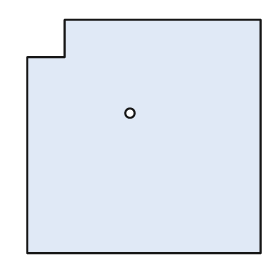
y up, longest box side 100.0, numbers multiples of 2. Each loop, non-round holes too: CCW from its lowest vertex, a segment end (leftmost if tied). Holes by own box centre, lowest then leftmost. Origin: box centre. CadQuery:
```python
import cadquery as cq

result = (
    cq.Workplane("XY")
    .moveTo(-50.0, -50.0)
    .lineTo(50.0, -50.0)
    .lineTo(50.0, 50.0)
    .lineTo(-34.0, 50.0)
    .lineTo(-34.0, 34.0)
    .lineTo(-50.0, 34.0)
    .close()
    .moveTo(-6.0, 10.0)
    .circle(2.0)
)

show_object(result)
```